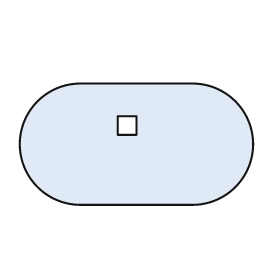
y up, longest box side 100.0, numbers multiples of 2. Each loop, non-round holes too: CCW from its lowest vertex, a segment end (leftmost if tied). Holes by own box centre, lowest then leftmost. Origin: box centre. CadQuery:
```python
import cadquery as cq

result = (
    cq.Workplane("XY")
    .moveTo(-24.0, -26.0)
    .lineTo(24.0, -26.0)
    .threePointArc((50.0, 0.0), (24.0, 26.0))
    .lineTo(-24.0, 26.0)
    .threePointArc((-50.0, 0.0), (-24.0, -26.0))
    .close()
    .moveTo(-8.0, 4.0)
    .lineTo(0.0, 4.0)
    .lineTo(0.0, 12.0)
    .lineTo(-8.0, 12.0)
    .close()
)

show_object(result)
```